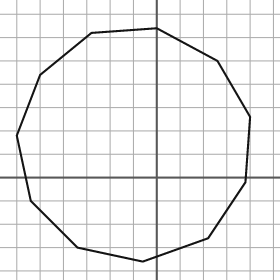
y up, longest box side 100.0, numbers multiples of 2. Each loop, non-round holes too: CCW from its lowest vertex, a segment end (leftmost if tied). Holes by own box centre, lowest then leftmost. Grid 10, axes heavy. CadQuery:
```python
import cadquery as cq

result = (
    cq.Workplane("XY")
    .moveTo(-6.0, -36.0)
    .lineTo(22.0, -26.0)
    .lineTo(38.0, -2.0)
    .lineTo(40.0, 26.0)
    .lineTo(26.0, 50.0)
    .lineTo(0.0, 64.0)
    .lineTo(-28.0, 62.0)
    .lineTo(-50.0, 44.0)
    .lineTo(-60.0, 18.0)
    .lineTo(-54.0, -10.0)
    .lineTo(-34.0, -30.0)
    .close()
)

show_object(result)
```